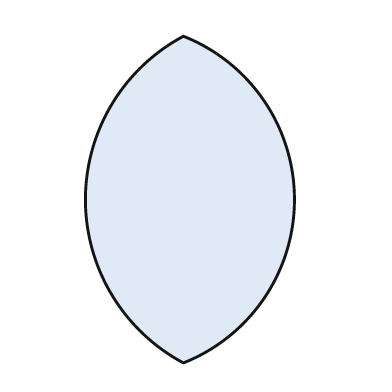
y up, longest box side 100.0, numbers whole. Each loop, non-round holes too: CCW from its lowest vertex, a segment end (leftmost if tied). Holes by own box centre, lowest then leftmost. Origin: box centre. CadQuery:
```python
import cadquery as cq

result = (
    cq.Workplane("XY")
    .moveTo(-2.0, -50.0)
    .threePointArc((32.0, 0.0), (-2.0, 50.0))
    .threePointArc((-32.0, 0.0), (-2.0, -50.0))
    .close()
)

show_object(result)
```